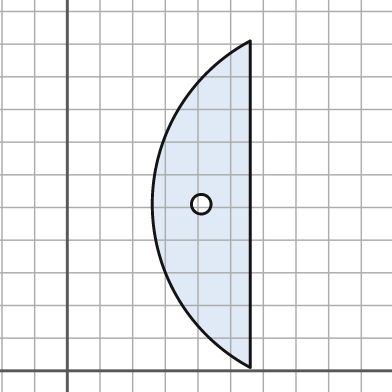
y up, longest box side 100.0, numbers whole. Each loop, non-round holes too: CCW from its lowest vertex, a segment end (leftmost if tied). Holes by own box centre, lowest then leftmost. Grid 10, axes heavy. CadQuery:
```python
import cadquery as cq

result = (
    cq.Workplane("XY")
    .moveTo(56.0, 1.0)
    .lineTo(56.0, 101.0)
    .threePointArc((26.0, 51.0), (56.0, 1.0))
    .close()
    .moveTo(41.0, 51.0)
    .circle(3.0)
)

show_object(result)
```